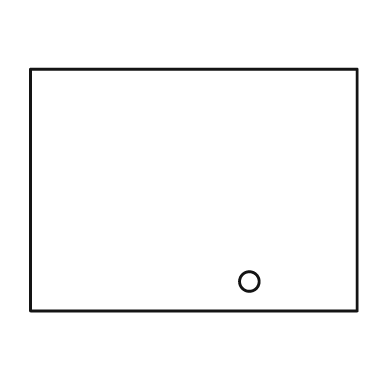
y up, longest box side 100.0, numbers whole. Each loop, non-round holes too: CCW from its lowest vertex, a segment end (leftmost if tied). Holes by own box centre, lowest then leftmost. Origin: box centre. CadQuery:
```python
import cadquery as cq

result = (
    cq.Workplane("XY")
    .moveTo(-50.0, -37.0)
    .lineTo(50.0, -37.0)
    .lineTo(50.0, 37.0)
    .lineTo(-50.0, 37.0)
    .close()
    .moveTo(17.0, -28.0)
    .circle(3.0)
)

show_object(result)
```